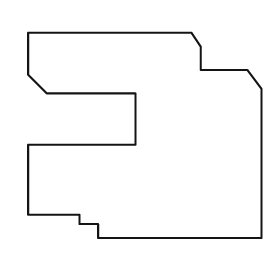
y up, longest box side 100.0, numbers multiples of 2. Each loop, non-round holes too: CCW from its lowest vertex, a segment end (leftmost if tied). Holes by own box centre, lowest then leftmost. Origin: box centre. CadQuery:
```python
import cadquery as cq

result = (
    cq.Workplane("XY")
    .moveTo(-20.0, -44.0)
    .lineTo(50.0, -44.0)
    .lineTo(50.0, 20.0)
    .lineTo(44.0, 28.0)
    .lineTo(24.0, 28.0)
    .lineTo(24.0, 38.0)
    .lineTo(20.0, 44.0)
    .lineTo(-50.0, 44.0)
    .lineTo(-50.0, 26.0)
    .lineTo(-42.0, 18.0)
    .lineTo(-4.0, 18.0)
    .lineTo(-4.0, -4.0)
    .lineTo(-50.0, -4.0)
    .lineTo(-50.0, -34.0)
    .lineTo(-28.0, -34.0)
    .lineTo(-28.0, -38.0)
    .lineTo(-20.0, -38.0)
    .close()
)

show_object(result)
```